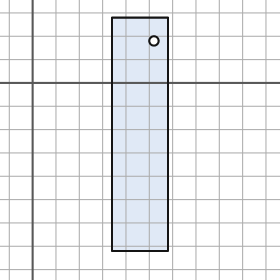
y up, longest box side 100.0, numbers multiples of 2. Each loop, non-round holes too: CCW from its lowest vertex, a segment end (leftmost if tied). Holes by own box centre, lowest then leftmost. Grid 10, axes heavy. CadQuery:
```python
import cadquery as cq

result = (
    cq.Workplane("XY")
    .moveTo(34.0, -72.0)
    .lineTo(58.0, -72.0)
    .lineTo(58.0, 28.0)
    .lineTo(34.0, 28.0)
    .close()
    .moveTo(52.0, 18.0)
    .circle(2.0)
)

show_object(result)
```